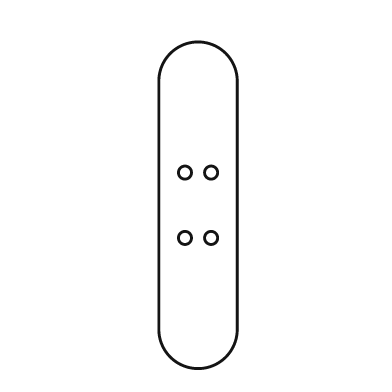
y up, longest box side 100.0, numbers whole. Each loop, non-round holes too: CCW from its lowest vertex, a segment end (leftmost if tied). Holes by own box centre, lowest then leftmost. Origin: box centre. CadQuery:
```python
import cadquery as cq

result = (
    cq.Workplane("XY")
    .moveTo(-12.0, -38.0)
    .threePointArc((0.0, -50.0), (12.0, -38.0))
    .lineTo(12.0, 38.0)
    .threePointArc((0.0, 50.0), (-12.0, 38.0))
    .close()
    .moveTo(-4.0, -10.0)
    .circle(2.0)
    .moveTo(4.0, -10.0)
    .circle(2.0)
    .moveTo(-4.0, 10.0)
    .circle(2.0)
    .moveTo(4.0, 10.0)
    .circle(2.0)
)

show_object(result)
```